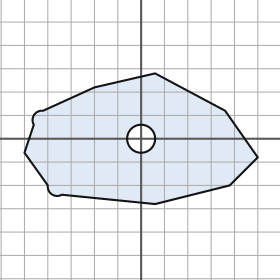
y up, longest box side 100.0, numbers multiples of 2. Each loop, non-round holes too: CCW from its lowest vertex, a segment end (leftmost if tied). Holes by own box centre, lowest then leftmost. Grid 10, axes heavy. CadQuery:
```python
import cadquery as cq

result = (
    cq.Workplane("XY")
    .moveTo(6.0, -28.0)
    .lineTo(38.0, -20.0)
    .lineTo(50.0, -8.0)
    .lineTo(36.0, 12.0)
    .lineTo(6.0, 28.0)
    .lineTo(-20.0, 22.0)
    .lineTo(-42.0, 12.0)
    .threePointArc((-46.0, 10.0), (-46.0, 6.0))
    .lineTo(-50.0, -6.0)
    .lineTo(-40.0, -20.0)
    .threePointArc((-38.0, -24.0), (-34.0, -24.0))
    .close()
    .moveTo(0.0, 0.0)
    .circle(6.0)
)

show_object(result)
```